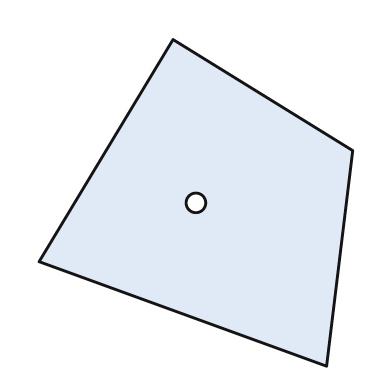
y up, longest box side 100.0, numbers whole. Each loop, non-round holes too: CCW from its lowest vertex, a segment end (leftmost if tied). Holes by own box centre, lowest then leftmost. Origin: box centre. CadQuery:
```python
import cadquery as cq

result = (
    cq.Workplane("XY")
    .moveTo(40.0, -50.0)
    .lineTo(48.0, 16.0)
    .lineTo(-7.0, 50.0)
    .lineTo(-48.0, -18.0)
    .close()
    .moveTo(0.0, 0.0)
    .circle(3.0)
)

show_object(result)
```